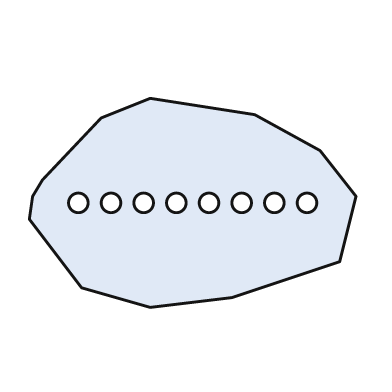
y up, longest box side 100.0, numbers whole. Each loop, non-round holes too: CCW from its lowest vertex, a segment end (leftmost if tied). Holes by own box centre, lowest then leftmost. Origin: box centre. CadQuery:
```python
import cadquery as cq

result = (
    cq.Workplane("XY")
    .moveTo(-13.0, -32.0)
    .lineTo(12.0, -29.0)
    .lineTo(45.0, -18.0)
    .lineTo(50.0, 2.0)
    .lineTo(39.0, 16.0)
    .lineTo(19.0, 27.0)
    .lineTo(-13.0, 32.0)
    .lineTo(-28.0, 26.0)
    .lineTo(-46.0, 7.0)
    .lineTo(-49.0, 2.0)
    .lineTo(-50.0, -5.0)
    .lineTo(-34.0, -26.0)
    .close()
    .moveTo(-35.0, 0.0)
    .circle(3.0)
    .moveTo(-25.0, 0.0)
    .circle(3.0)
    .moveTo(-15.0, 0.0)
    .circle(3.0)
    .moveTo(-5.0, 0.0)
    .circle(3.0)
    .moveTo(5.0, 0.0)
    .circle(3.0)
    .moveTo(15.0, 0.0)
    .circle(3.0)
    .moveTo(25.0, 0.0)
    .circle(3.0)
    .moveTo(35.0, 0.0)
    .circle(3.0)
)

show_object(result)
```